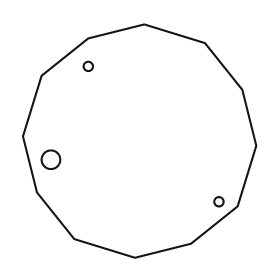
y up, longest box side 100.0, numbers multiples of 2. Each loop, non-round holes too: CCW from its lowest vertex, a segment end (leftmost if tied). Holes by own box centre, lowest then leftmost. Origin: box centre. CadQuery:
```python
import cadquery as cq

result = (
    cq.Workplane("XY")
    .moveTo(-2.0, -50.0)
    .lineTo(22.0, -44.0)
    .lineTo(42.0, -28.0)
    .lineTo(50.0, -2.0)
    .lineTo(44.0, 22.0)
    .lineTo(28.0, 42.0)
    .lineTo(2.0, 50.0)
    .lineTo(-22.0, 44.0)
    .lineTo(-42.0, 28.0)
    .lineTo(-50.0, 2.0)
    .lineTo(-44.0, -22.0)
    .lineTo(-28.0, -42.0)
    .close()
    .moveTo(34.0, -26.0)
    .circle(2.0)
    .moveTo(-38.0, -8.0)
    .circle(4.0)
    .moveTo(-22.0, 32.0)
    .circle(2.0)
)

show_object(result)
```